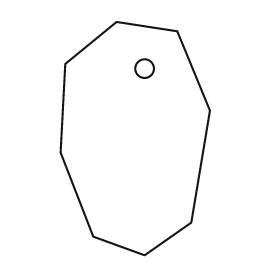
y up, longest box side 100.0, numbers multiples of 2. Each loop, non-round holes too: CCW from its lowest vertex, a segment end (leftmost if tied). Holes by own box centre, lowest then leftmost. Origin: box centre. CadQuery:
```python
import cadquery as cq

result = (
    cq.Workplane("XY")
    .moveTo(4.0, -50.0)
    .lineTo(24.0, -36.0)
    .lineTo(32.0, 12.0)
    .lineTo(18.0, 46.0)
    .lineTo(-8.0, 50.0)
    .lineTo(-30.0, 32.0)
    .lineTo(-32.0, -6.0)
    .lineTo(-18.0, -42.0)
    .close()
    .moveTo(4.0, 30.0)
    .circle(4.0)
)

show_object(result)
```